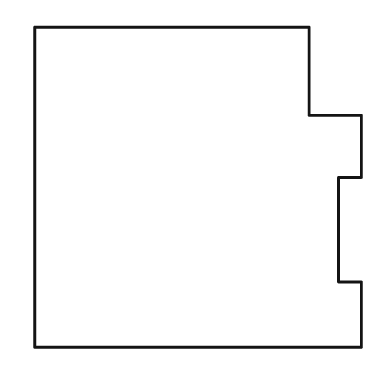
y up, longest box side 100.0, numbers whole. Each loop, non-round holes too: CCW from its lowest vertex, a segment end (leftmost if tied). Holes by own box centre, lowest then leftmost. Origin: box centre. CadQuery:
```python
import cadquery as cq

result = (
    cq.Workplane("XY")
    .moveTo(-50.0, -49.0)
    .lineTo(50.0, -49.0)
    .lineTo(50.0, -29.0)
    .lineTo(43.0, -29.0)
    .lineTo(43.0, 3.0)
    .lineTo(50.0, 3.0)
    .lineTo(50.0, 22.0)
    .lineTo(34.0, 22.0)
    .lineTo(34.0, 49.0)
    .lineTo(-50.0, 49.0)
    .close()
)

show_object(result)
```